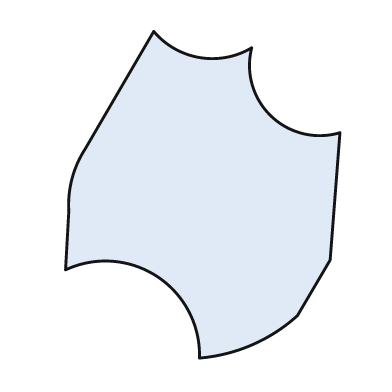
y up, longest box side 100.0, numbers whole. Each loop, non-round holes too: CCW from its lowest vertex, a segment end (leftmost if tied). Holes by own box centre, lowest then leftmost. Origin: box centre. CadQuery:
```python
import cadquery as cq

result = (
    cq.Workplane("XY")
    .moveTo(-1.0, -50.0)
    .threePointArc((15.0, -46.0), (29.0, -37.0))
    .lineTo(39.0, -20.0)
    .lineTo(42.0, 19.0)
    .threePointArc((21.0, 24.0), (15.0, 45.0))
    .threePointArc((-1.0, 42.0), (-15.0, 50.0))
    .lineTo(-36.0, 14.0)
    .threePointArc((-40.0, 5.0), (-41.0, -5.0))
    .lineTo(-42.0, -23.0)
    .threePointArc((-14.0, -25.0), (-1.0, -50.0))
    .close()
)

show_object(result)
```